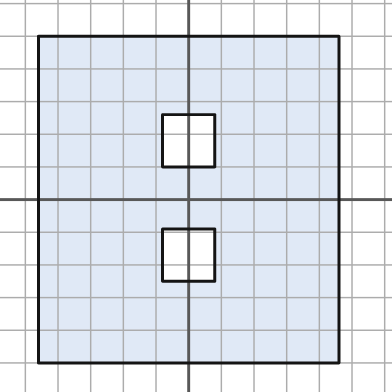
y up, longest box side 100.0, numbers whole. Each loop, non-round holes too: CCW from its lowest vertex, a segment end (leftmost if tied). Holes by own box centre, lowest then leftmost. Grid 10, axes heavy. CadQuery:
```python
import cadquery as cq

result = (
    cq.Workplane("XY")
    .moveTo(-46.0, -50.0)
    .lineTo(46.0, -50.0)
    .lineTo(46.0, 50.0)
    .lineTo(-46.0, 50.0)
    .close()
    .moveTo(-8.0, -25.0)
    .lineTo(8.0, -25.0)
    .lineTo(8.0, -9.0)
    .lineTo(-8.0, -9.0)
    .close()
    .moveTo(-8.0, 10.0)
    .lineTo(8.0, 10.0)
    .lineTo(8.0, 26.0)
    .lineTo(-8.0, 26.0)
    .close()
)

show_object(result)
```